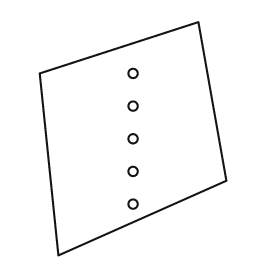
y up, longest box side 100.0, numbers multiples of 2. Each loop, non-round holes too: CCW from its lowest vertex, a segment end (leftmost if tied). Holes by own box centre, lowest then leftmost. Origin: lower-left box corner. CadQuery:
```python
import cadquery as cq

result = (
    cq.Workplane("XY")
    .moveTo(8.0, 0.0)
    .lineTo(80.0, 32.0)
    .lineTo(68.0, 100.0)
    .lineTo(0.0, 78.0)
    .close()
    .moveTo(40.0, 22.0)
    .circle(2.0)
    .moveTo(40.0, 36.0)
    .circle(2.0)
    .moveTo(40.0, 50.0)
    .circle(2.0)
    .moveTo(40.0, 64.0)
    .circle(2.0)
    .moveTo(40.0, 78.0)
    .circle(2.0)
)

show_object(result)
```